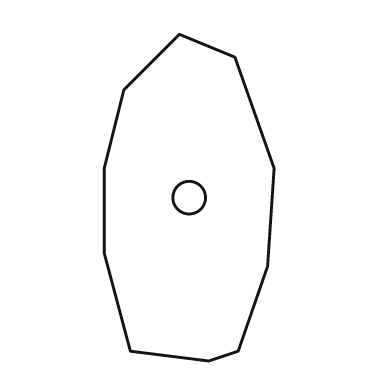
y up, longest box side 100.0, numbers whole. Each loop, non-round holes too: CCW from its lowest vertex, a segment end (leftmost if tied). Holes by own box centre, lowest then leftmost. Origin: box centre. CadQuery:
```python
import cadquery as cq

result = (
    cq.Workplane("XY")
    .moveTo(6.0, -50.0)
    .lineTo(15.0, -47.0)
    .lineTo(24.0, -21.0)
    .lineTo(26.0, 9.0)
    .lineTo(14.0, 43.0)
    .lineTo(-3.0, 50.0)
    .lineTo(-20.0, 33.0)
    .lineTo(-26.0, 9.0)
    .lineTo(-26.0, -17.0)
    .lineTo(-18.0, -47.0)
    .close()
    .moveTo(0.0, 0.0)
    .circle(5.0)
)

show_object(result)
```